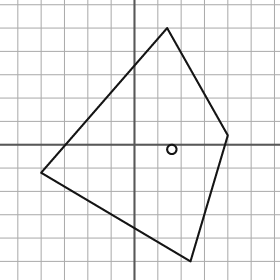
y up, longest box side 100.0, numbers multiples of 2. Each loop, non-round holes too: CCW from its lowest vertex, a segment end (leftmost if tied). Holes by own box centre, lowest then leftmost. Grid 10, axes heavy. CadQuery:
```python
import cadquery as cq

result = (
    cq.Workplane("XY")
    .moveTo(24.0, -50.0)
    .lineTo(40.0, 4.0)
    .lineTo(14.0, 50.0)
    .lineTo(-40.0, -12.0)
    .close()
    .moveTo(16.0, -2.0)
    .circle(2.0)
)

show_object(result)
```